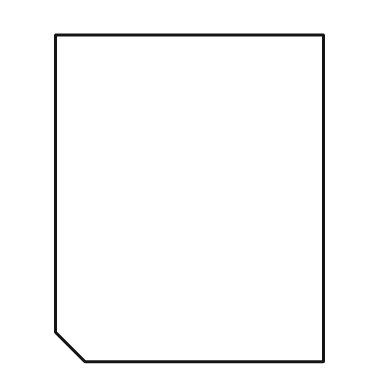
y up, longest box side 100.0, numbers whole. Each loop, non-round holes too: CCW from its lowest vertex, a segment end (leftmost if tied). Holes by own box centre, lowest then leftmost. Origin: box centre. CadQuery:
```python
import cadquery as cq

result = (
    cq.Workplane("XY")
    .moveTo(-32.0, -50.0)
    .lineTo(41.0, -50.0)
    .lineTo(41.0, 50.0)
    .lineTo(-41.0, 50.0)
    .lineTo(-41.0, -41.0)
    .close()
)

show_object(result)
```